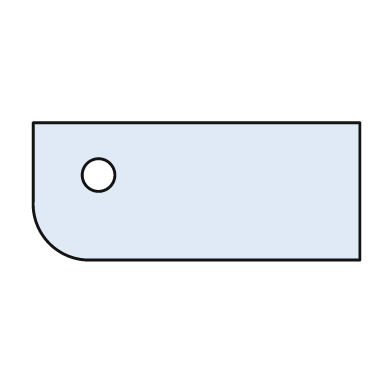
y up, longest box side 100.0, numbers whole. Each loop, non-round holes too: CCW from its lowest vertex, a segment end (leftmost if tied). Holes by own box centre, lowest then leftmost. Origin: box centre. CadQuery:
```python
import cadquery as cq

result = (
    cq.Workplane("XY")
    .moveTo(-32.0, -21.0)
    .lineTo(50.0, -21.0)
    .lineTo(50.0, 21.0)
    .lineTo(-50.0, 21.0)
    .lineTo(-50.0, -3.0)
    .threePointArc((-45.0, -16.0), (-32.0, -21.0))
    .close()
    .moveTo(-30.0, 5.0)
    .circle(5.0)
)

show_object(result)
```